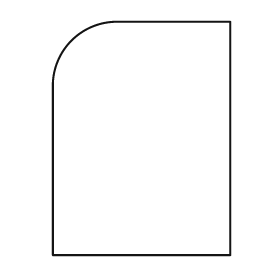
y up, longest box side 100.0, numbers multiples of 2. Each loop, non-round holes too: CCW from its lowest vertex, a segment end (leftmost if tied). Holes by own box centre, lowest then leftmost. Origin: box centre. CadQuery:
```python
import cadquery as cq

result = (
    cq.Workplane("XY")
    .moveTo(-38.0, -50.0)
    .lineTo(38.0, -50.0)
    .lineTo(38.0, 50.0)
    .lineTo(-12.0, 50.0)
    .threePointArc((-30.0, 42.0), (-38.0, 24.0))
    .close()
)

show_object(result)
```